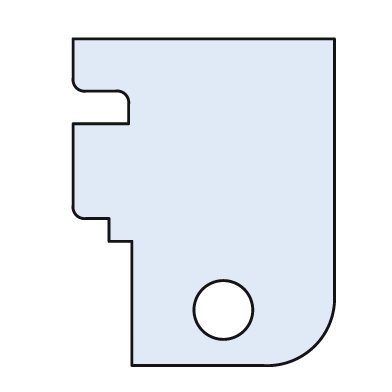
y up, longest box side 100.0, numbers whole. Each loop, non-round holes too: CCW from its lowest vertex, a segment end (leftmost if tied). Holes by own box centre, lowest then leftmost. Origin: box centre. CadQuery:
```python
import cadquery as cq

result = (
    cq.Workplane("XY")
    .moveTo(-22.0, -50.0)
    .lineTo(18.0, -50.0)
    .threePointArc((34.0, -44.0), (40.0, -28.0))
    .lineTo(40.0, 50.0)
    .lineTo(-40.0, 50.0)
    .lineTo(-40.0, 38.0)
    .threePointArc((-39.0, 35.0), (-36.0, 34.0))
    .lineTo(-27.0, 34.0)
    .threePointArc((-24.0, 33.0), (-23.0, 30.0))
    .lineTo(-23.0, 24.0)
    .lineTo(-40.0, 24.0)
    .lineTo(-40.0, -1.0)
    .threePointArc((-39.0, -4.0), (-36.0, -5.0))
    .lineTo(-29.0, -5.0)
    .lineTo(-29.0, -12.0)
    .lineTo(-22.0, -12.0)
    .close()
    .moveTo(6.0, -33.0)
    .circle(9.0)
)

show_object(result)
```